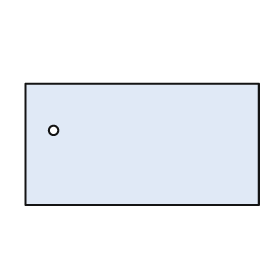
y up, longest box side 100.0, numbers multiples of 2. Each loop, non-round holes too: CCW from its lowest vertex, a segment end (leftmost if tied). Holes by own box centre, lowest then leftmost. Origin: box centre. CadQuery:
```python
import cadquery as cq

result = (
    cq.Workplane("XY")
    .moveTo(-50.0, -26.0)
    .lineTo(50.0, -26.0)
    .lineTo(50.0, 26.0)
    .lineTo(-50.0, 26.0)
    .close()
    .moveTo(-38.0, 6.0)
    .circle(2.0)
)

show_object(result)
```